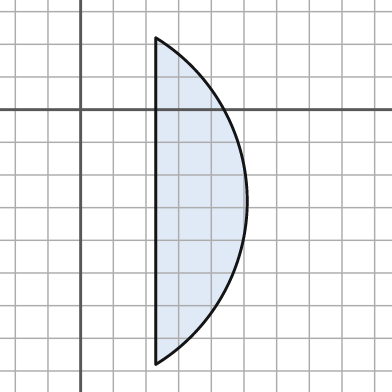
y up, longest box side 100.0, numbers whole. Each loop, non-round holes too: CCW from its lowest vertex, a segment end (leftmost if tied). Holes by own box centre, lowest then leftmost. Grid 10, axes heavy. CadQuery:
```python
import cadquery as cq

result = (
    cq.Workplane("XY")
    .moveTo(23.0, -78.0)
    .threePointArc((51.0, -28.0), (23.0, 22.0))
    .close()
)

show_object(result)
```